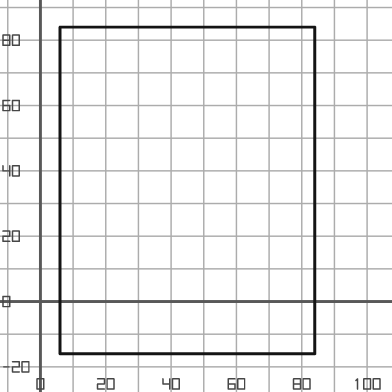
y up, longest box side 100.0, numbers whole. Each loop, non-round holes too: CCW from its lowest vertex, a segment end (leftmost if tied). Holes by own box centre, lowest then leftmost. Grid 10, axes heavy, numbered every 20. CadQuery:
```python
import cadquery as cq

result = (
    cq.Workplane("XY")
    .moveTo(6.0, -16.0)
    .lineTo(84.0, -16.0)
    .lineTo(84.0, 84.0)
    .lineTo(6.0, 84.0)
    .close()
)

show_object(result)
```